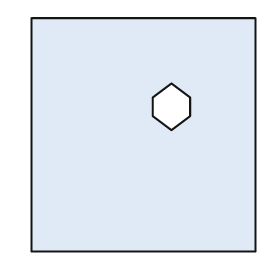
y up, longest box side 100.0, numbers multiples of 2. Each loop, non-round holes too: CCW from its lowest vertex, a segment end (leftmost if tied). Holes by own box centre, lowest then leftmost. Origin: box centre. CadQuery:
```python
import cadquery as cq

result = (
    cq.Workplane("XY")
    .moveTo(-48.0, -50.0)
    .lineTo(48.0, -50.0)
    .lineTo(48.0, 50.0)
    .lineTo(-48.0, 50.0)
    .close()
    .moveTo(12.0, 2.0)
    .lineTo(20.0, 8.0)
    .lineTo(20.0, 16.0)
    .lineTo(12.0, 22.0)
    .lineTo(4.0, 16.0)
    .lineTo(4.0, 8.0)
    .close()
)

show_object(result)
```